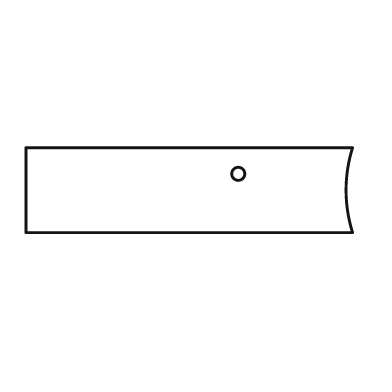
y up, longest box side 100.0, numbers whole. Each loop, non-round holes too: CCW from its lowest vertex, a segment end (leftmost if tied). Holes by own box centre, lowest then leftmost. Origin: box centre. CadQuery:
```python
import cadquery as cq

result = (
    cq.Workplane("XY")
    .moveTo(-50.0, -13.0)
    .lineTo(50.0, -13.0)
    .threePointArc((48.0, 0.0), (50.0, 13.0))
    .lineTo(-50.0, 13.0)
    .close()
    .moveTo(15.0, 5.0)
    .circle(2.0)
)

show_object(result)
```